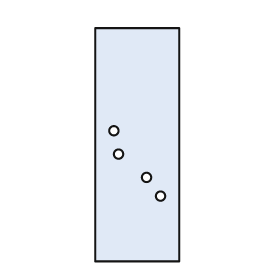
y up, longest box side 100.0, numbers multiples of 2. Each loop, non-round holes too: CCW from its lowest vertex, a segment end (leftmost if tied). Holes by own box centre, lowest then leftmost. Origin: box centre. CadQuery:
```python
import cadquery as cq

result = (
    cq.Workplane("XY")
    .moveTo(-18.0, -50.0)
    .lineTo(18.0, -50.0)
    .lineTo(18.0, 50.0)
    .lineTo(-18.0, 50.0)
    .close()
    .moveTo(10.0, -22.0)
    .circle(2.0)
    .moveTo(4.0, -14.0)
    .circle(2.0)
    .moveTo(-8.0, -4.0)
    .circle(2.0)
    .moveTo(-10.0, 6.0)
    .circle(2.0)
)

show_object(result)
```